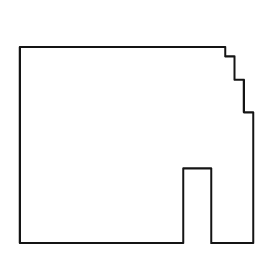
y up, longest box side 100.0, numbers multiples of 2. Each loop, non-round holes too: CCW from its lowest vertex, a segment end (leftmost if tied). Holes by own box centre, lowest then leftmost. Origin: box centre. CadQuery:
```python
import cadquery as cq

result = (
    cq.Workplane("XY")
    .moveTo(-50.0, -42.0)
    .lineTo(20.0, -42.0)
    .lineTo(20.0, -10.0)
    .lineTo(32.0, -10.0)
    .lineTo(32.0, -42.0)
    .lineTo(50.0, -42.0)
    .lineTo(50.0, 14.0)
    .lineTo(46.0, 14.0)
    .lineTo(46.0, 28.0)
    .lineTo(42.0, 28.0)
    .lineTo(42.0, 38.0)
    .lineTo(38.0, 38.0)
    .lineTo(38.0, 42.0)
    .lineTo(-50.0, 42.0)
    .close()
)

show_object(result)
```